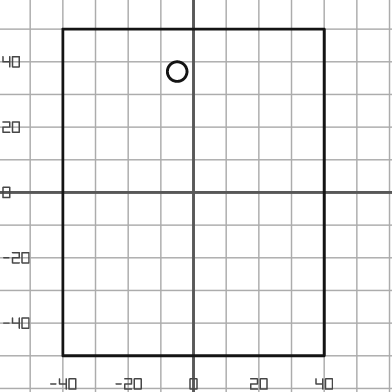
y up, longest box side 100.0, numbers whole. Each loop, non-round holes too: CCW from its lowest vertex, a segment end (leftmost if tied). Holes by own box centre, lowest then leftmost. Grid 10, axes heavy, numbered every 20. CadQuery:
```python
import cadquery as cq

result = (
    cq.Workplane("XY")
    .moveTo(-40.0, -50.0)
    .lineTo(40.0, -50.0)
    .lineTo(40.0, 50.0)
    .lineTo(-40.0, 50.0)
    .close()
    .moveTo(-5.0, 37.0)
    .circle(3.0)
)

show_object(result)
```